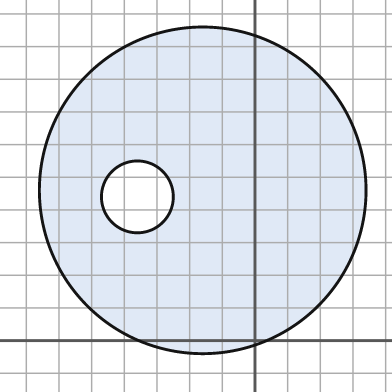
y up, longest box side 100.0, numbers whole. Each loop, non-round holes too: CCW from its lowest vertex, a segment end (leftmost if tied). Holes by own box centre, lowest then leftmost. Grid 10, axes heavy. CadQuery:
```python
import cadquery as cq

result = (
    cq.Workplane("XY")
    .moveTo(-16.0, 46.0)
    .circle(50.0)
    .moveTo(-36.0, 44.0)
    .circle(11.0)
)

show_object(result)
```